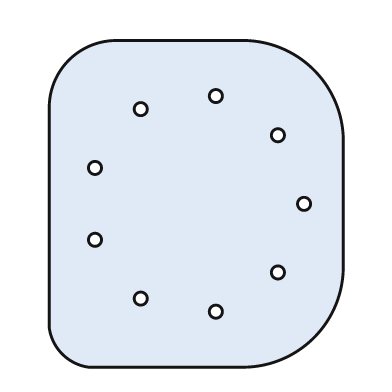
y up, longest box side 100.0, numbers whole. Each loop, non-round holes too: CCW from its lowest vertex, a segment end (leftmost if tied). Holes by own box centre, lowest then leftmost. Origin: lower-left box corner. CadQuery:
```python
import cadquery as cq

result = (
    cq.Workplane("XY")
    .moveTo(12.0, 0.0)
    .lineTo(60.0, 0.0)
    .threePointArc((81.0, 9.0), (90.0, 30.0))
    .lineTo(90.0, 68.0)
    .threePointArc((81.0, 91.0), (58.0, 100.0))
    .lineTo(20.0, 100.0)
    .threePointArc((6.0, 94.0), (0.0, 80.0))
    .lineTo(0.0, 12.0)
    .threePointArc((4.0, 4.0), (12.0, 0.0))
    .close()
    .moveTo(51.0, 17.0)
    .circle(2.0)
    .moveTo(28.0, 21.0)
    .circle(2.0)
    .moveTo(70.0, 29.0)
    .circle(2.0)
    .moveTo(14.0, 39.0)
    .circle(2.0)
    .moveTo(78.0, 50.0)
    .circle(2.0)
    .moveTo(14.0, 61.0)
    .circle(2.0)
    .moveTo(70.0, 71.0)
    .circle(2.0)
    .moveTo(28.0, 79.0)
    .circle(2.0)
    .moveTo(51.0, 83.0)
    .circle(2.0)
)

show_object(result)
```